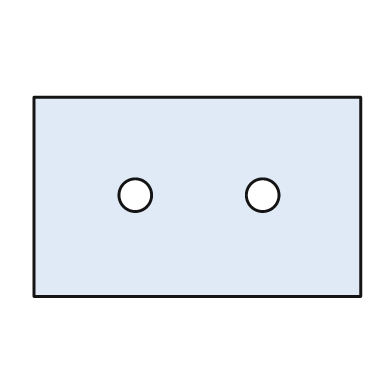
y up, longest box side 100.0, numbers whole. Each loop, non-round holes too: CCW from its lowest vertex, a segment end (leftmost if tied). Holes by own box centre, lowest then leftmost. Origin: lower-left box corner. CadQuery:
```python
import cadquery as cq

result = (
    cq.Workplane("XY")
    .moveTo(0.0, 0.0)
    .lineTo(100.0, 0.0)
    .lineTo(100.0, 61.0)
    .lineTo(0.0, 61.0)
    .close()
    .moveTo(31.0, 31.0)
    .circle(5.0)
    .moveTo(70.0, 31.0)
    .circle(5.0)
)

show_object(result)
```